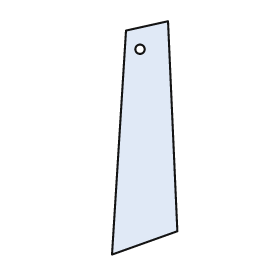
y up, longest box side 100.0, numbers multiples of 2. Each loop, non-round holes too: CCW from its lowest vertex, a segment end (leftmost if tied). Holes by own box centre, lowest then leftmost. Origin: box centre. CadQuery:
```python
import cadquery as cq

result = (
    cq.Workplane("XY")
    .moveTo(-14.0, -50.0)
    .lineTo(14.0, -40.0)
    .lineTo(10.0, 50.0)
    .lineTo(-8.0, 46.0)
    .close()
    .moveTo(-2.0, 38.0)
    .circle(2.0)
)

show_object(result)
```